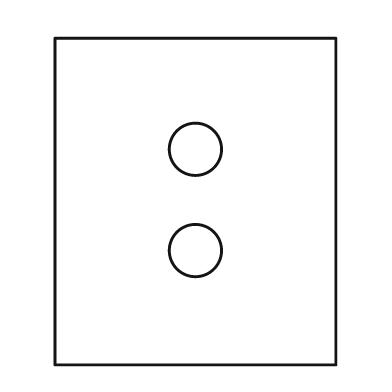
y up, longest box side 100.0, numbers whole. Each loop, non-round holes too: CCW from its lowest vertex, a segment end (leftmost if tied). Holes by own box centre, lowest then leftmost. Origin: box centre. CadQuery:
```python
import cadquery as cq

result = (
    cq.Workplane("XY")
    .moveTo(-43.0, -50.0)
    .lineTo(43.0, -50.0)
    .lineTo(43.0, 50.0)
    .lineTo(-43.0, 50.0)
    .close()
    .moveTo(0.0, -15.0)
    .circle(8.0)
    .moveTo(0.0, 16.0)
    .circle(8.0)
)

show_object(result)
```